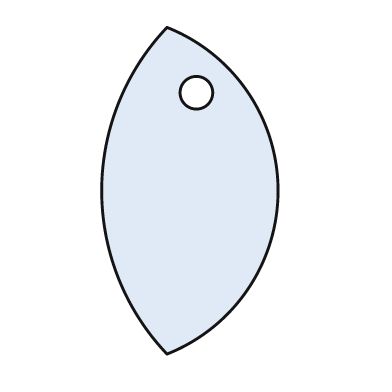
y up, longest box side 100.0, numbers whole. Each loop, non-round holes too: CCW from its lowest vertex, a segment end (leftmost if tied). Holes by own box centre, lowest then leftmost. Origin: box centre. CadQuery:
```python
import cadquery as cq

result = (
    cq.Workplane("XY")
    .moveTo(-7.0, -50.0)
    .threePointArc((27.0, 0.0), (-7.0, 50.0))
    .threePointArc((-27.0, 0.0), (-7.0, -50.0))
    .close()
    .moveTo(2.0, 30.0)
    .circle(5.0)
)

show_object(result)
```